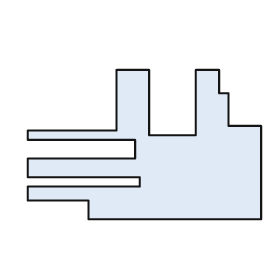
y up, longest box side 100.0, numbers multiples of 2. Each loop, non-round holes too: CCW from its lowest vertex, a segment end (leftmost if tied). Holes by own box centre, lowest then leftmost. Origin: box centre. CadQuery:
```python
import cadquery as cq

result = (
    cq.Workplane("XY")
    .moveTo(-24.0, -32.0)
    .lineTo(50.0, -32.0)
    .lineTo(50.0, 8.0)
    .lineTo(36.0, 8.0)
    .lineTo(36.0, 22.0)
    .lineTo(32.0, 22.0)
    .lineTo(32.0, 32.0)
    .lineTo(22.0, 32.0)
    .lineTo(22.0, 4.0)
    .lineTo(2.0, 4.0)
    .lineTo(2.0, 32.0)
    .lineTo(-12.0, 32.0)
    .lineTo(-12.0, 6.0)
    .lineTo(-50.0, 6.0)
    .lineTo(-50.0, 2.0)
    .lineTo(-4.0, 2.0)
    .lineTo(-4.0, -6.0)
    .lineTo(-50.0, -6.0)
    .lineTo(-50.0, -14.0)
    .lineTo(-2.0, -14.0)
    .lineTo(-2.0, -18.0)
    .lineTo(-50.0, -18.0)
    .lineTo(-50.0, -24.0)
    .lineTo(-24.0, -24.0)
    .close()
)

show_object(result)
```